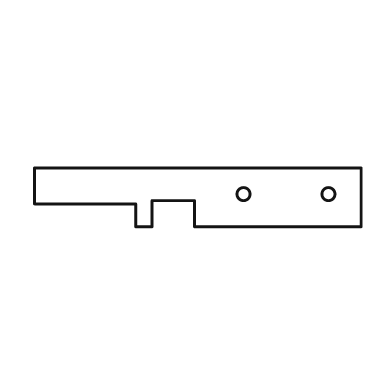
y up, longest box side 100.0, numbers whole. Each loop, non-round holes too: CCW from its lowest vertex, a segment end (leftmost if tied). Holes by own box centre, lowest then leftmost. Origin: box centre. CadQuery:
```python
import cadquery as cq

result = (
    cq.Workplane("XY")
    .moveTo(-19.0, -9.0)
    .lineTo(-14.0, -9.0)
    .lineTo(-14.0, -1.0)
    .lineTo(-1.0, -1.0)
    .lineTo(-1.0, -9.0)
    .lineTo(50.0, -9.0)
    .lineTo(50.0, 9.0)
    .lineTo(-50.0, 9.0)
    .lineTo(-50.0, -2.0)
    .lineTo(-19.0, -2.0)
    .close()
    .moveTo(14.0, 1.0)
    .circle(2.0)
    .moveTo(40.0, 1.0)
    .circle(2.0)
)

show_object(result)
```